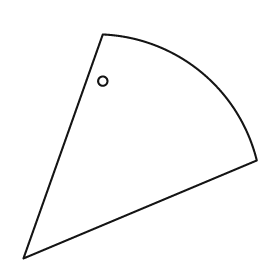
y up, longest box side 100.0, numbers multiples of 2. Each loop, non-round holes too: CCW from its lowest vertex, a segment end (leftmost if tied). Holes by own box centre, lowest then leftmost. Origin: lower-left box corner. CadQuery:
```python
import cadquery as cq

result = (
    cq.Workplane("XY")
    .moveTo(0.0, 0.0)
    .lineTo(100.0, 42.0)
    .threePointArc((76.0, 80.0), (34.0, 96.0))
    .close()
    .moveTo(34.0, 76.0)
    .circle(2.0)
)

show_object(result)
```